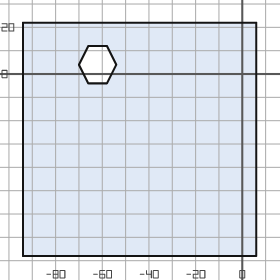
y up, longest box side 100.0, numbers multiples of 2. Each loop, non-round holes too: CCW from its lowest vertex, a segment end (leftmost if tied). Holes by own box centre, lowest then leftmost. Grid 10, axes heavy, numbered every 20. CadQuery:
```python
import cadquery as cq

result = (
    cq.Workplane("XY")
    .moveTo(-94.0, -78.0)
    .lineTo(6.0, -78.0)
    .lineTo(6.0, 22.0)
    .lineTo(-94.0, 22.0)
    .close()
    .moveTo(-66.0, -4.0)
    .lineTo(-58.0, -4.0)
    .lineTo(-54.0, 4.0)
    .lineTo(-58.0, 12.0)
    .lineTo(-66.0, 12.0)
    .lineTo(-70.0, 4.0)
    .close()
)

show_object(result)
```